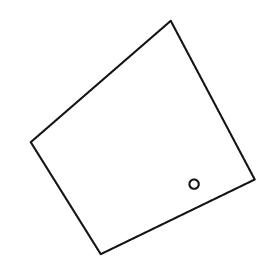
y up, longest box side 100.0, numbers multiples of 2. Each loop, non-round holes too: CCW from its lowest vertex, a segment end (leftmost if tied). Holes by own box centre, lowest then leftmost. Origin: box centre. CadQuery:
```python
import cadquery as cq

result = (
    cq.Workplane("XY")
    .moveTo(-18.0, -50.0)
    .lineTo(48.0, -18.0)
    .lineTo(12.0, 50.0)
    .lineTo(-48.0, -2.0)
    .close()
    .moveTo(22.0, -20.0)
    .circle(2.0)
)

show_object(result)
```